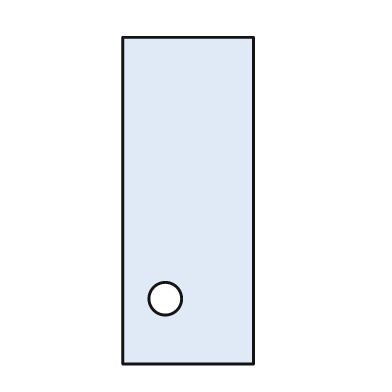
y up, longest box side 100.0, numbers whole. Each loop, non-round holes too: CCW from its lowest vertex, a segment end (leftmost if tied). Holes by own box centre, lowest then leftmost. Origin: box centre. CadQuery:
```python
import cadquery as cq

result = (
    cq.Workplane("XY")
    .moveTo(-20.0, -50.0)
    .lineTo(20.0, -50.0)
    .lineTo(20.0, 50.0)
    .lineTo(-20.0, 50.0)
    .close()
    .moveTo(-7.0, -30.0)
    .circle(5.0)
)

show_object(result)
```